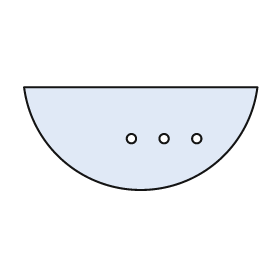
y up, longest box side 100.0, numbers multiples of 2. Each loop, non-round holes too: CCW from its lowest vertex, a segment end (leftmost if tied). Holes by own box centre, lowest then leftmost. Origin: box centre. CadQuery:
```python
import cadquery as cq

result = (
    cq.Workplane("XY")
    .moveTo(-50.0, 22.0)
    .threePointArc((0.0, -22.0), (50.0, 22.0))
    .close()
    .moveTo(-4.0, 0.0)
    .circle(2.0)
    .moveTo(10.0, 0.0)
    .circle(2.0)
    .moveTo(24.0, 0.0)
    .circle(2.0)
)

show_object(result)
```